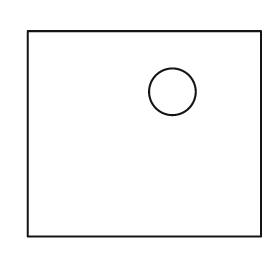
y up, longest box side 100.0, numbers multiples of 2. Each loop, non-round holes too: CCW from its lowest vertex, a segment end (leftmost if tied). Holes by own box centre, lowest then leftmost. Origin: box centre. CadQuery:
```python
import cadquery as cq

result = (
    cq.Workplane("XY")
    .moveTo(-50.0, -44.0)
    .lineTo(50.0, -44.0)
    .lineTo(50.0, 44.0)
    .lineTo(-50.0, 44.0)
    .close()
    .moveTo(12.0, 18.0)
    .circle(10.0)
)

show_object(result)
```